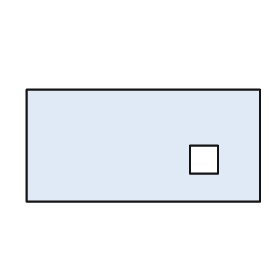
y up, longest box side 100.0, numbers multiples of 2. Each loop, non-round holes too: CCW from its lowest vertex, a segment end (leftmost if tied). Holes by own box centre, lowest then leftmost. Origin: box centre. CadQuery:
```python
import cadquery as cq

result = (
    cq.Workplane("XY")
    .moveTo(-50.0, -24.0)
    .lineTo(50.0, -24.0)
    .lineTo(50.0, 24.0)
    .lineTo(-50.0, 24.0)
    .close()
    .moveTo(20.0, -12.0)
    .lineTo(32.0, -12.0)
    .lineTo(32.0, 0.0)
    .lineTo(20.0, 0.0)
    .close()
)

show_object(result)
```